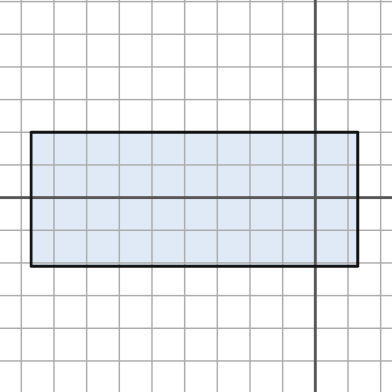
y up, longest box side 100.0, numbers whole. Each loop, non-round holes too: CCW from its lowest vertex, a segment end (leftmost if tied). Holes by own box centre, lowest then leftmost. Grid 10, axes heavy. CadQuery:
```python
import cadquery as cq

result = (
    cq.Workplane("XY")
    .moveTo(-87.0, -21.0)
    .lineTo(13.0, -21.0)
    .lineTo(13.0, 20.0)
    .lineTo(-87.0, 20.0)
    .close()
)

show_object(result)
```